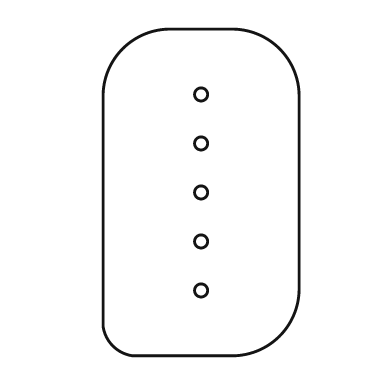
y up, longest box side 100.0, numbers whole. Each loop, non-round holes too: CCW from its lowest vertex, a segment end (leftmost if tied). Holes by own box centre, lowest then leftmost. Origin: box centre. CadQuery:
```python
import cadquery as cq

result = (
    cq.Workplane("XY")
    .moveTo(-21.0, -50.0)
    .lineTo(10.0, -50.0)
    .threePointArc((24.0, -44.0), (30.0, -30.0))
    .lineTo(30.0, 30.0)
    .threePointArc((24.0, 44.0), (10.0, 50.0))
    .lineTo(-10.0, 50.0)
    .threePointArc((-24.0, 44.0), (-30.0, 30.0))
    .lineTo(-30.0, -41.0)
    .threePointArc((-27.0, -47.0), (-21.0, -50.0))
    .close()
    .moveTo(0.0, -30.0)
    .circle(2.0)
    .moveTo(0.0, -15.0)
    .circle(2.0)
    .moveTo(0.0, 0.0)
    .circle(2.0)
    .moveTo(0.0, 15.0)
    .circle(2.0)
    .moveTo(0.0, 30.0)
    .circle(2.0)
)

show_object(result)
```